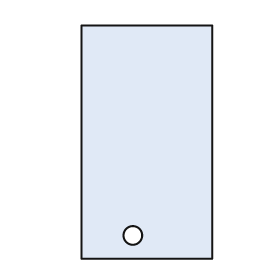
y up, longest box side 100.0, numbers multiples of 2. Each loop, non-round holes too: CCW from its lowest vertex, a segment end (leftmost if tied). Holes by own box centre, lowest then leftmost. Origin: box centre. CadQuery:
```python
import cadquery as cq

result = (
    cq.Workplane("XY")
    .moveTo(-28.0, -50.0)
    .lineTo(28.0, -50.0)
    .lineTo(28.0, 50.0)
    .lineTo(-28.0, 50.0)
    .close()
    .moveTo(-6.0, -40.0)
    .circle(4.0)
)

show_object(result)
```